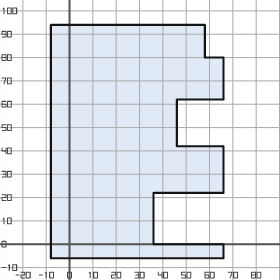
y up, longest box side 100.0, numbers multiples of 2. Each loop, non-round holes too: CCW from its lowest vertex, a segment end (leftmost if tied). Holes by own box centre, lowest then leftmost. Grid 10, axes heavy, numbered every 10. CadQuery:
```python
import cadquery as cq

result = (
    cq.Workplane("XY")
    .moveTo(-8.0, -6.0)
    .lineTo(66.0, -6.0)
    .lineTo(66.0, 0.0)
    .lineTo(36.0, 0.0)
    .lineTo(36.0, 22.0)
    .lineTo(66.0, 22.0)
    .lineTo(66.0, 42.0)
    .lineTo(46.0, 42.0)
    .lineTo(46.0, 62.0)
    .lineTo(66.0, 62.0)
    .lineTo(66.0, 80.0)
    .lineTo(58.0, 80.0)
    .lineTo(58.0, 94.0)
    .lineTo(-8.0, 94.0)
    .close()
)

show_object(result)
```